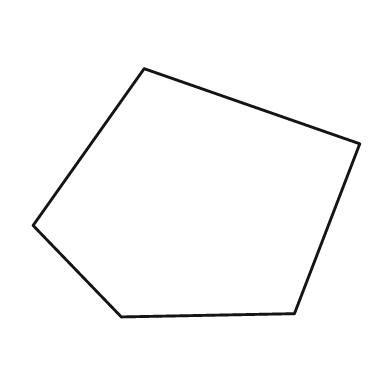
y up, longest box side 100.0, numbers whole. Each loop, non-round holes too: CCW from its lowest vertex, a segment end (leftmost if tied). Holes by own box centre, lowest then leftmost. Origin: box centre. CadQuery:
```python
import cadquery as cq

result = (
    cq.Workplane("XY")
    .moveTo(-23.0, -38.0)
    .lineTo(30.0, -37.0)
    .lineTo(50.0, 15.0)
    .lineTo(-16.0, 38.0)
    .lineTo(-50.0, -10.0)
    .close()
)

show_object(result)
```